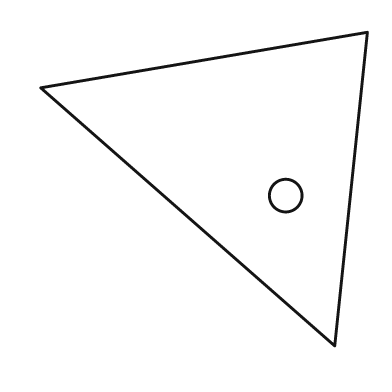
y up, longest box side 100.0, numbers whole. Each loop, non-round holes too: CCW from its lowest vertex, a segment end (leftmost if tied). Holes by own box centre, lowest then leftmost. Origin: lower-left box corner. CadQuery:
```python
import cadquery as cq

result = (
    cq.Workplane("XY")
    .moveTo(90.0, 0.0)
    .lineTo(100.0, 96.0)
    .lineTo(0.0, 79.0)
    .close()
    .moveTo(75.0, 46.0)
    .circle(5.0)
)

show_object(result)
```